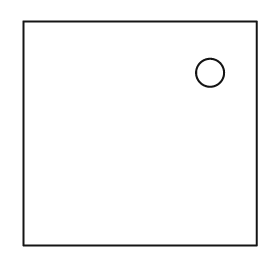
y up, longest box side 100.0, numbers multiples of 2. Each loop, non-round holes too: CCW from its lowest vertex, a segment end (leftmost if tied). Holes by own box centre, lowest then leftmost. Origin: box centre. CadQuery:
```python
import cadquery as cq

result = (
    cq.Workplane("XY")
    .moveTo(-50.0, -48.0)
    .lineTo(50.0, -48.0)
    .lineTo(50.0, 48.0)
    .lineTo(-50.0, 48.0)
    .close()
    .moveTo(30.0, 26.0)
    .circle(6.0)
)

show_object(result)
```